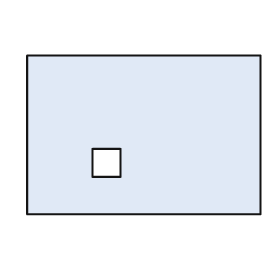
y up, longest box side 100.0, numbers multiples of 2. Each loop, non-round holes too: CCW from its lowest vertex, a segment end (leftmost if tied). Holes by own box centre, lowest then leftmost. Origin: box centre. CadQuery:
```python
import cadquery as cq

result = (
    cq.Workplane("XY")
    .moveTo(-50.0, -34.0)
    .lineTo(50.0, -34.0)
    .lineTo(50.0, 34.0)
    .lineTo(-50.0, 34.0)
    .close()
    .moveTo(-22.0, -18.0)
    .lineTo(-10.0, -18.0)
    .lineTo(-10.0, -6.0)
    .lineTo(-22.0, -6.0)
    .close()
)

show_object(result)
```